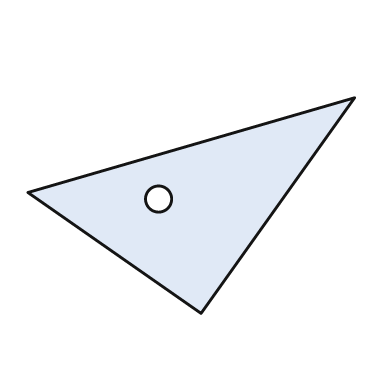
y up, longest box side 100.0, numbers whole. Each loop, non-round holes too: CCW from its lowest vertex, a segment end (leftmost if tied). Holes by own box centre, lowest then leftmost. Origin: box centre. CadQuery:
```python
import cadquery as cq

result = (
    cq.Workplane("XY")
    .moveTo(3.0, -33.0)
    .lineTo(50.0, 33.0)
    .lineTo(-50.0, 4.0)
    .close()
    .moveTo(-10.0, 2.0)
    .circle(4.0)
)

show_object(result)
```